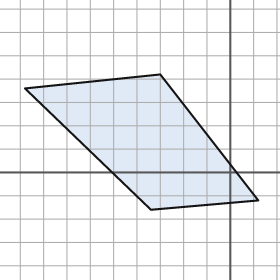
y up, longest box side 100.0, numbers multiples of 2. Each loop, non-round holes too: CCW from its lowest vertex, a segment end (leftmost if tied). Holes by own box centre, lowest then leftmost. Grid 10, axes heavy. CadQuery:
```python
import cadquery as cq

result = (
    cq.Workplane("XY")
    .moveTo(-34.0, -16.0)
    .lineTo(12.0, -12.0)
    .lineTo(-30.0, 42.0)
    .lineTo(-88.0, 36.0)
    .close()
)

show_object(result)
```